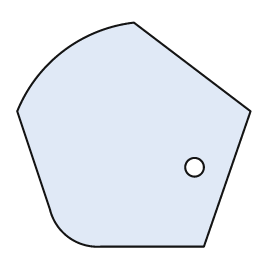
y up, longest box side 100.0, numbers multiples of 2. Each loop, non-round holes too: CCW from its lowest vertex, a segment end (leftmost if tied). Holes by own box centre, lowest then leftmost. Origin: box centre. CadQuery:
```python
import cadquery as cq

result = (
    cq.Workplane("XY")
    .moveTo(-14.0, -48.0)
    .lineTo(30.0, -48.0)
    .lineTo(50.0, 10.0)
    .lineTo(0.0, 48.0)
    .threePointArc((-30.0, 36.0), (-50.0, 10.0))
    .lineTo(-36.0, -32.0)
    .threePointArc((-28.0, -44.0), (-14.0, -48.0))
    .close()
    .moveTo(26.0, -14.0)
    .circle(4.0)
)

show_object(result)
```